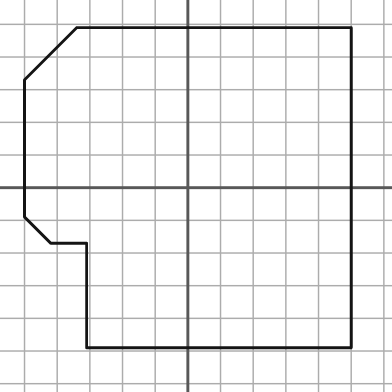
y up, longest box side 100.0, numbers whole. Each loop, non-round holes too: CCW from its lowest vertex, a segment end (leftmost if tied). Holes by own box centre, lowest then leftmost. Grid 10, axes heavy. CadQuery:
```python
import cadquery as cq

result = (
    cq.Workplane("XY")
    .moveTo(-31.0, -49.0)
    .lineTo(50.0, -49.0)
    .lineTo(50.0, 49.0)
    .lineTo(-34.0, 49.0)
    .lineTo(-50.0, 33.0)
    .lineTo(-50.0, -9.0)
    .lineTo(-42.0, -17.0)
    .lineTo(-31.0, -17.0)
    .close()
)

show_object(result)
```